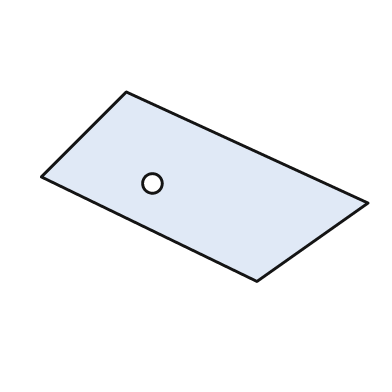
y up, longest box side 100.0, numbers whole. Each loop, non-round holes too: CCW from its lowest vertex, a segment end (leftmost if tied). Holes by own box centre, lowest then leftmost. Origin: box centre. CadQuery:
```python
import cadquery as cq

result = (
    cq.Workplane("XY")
    .moveTo(16.0, -29.0)
    .lineTo(50.0, -5.0)
    .lineTo(-24.0, 29.0)
    .lineTo(-50.0, 3.0)
    .close()
    .moveTo(-16.0, 1.0)
    .circle(3.0)
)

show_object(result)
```